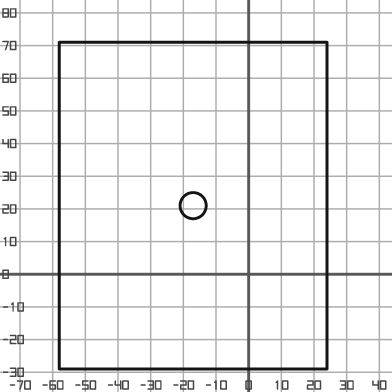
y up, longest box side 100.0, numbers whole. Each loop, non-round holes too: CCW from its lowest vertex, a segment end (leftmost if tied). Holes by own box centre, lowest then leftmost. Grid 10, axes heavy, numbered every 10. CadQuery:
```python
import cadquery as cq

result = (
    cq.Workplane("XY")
    .moveTo(-58.0, -29.0)
    .lineTo(24.0, -29.0)
    .lineTo(24.0, 71.0)
    .lineTo(-58.0, 71.0)
    .close()
    .moveTo(-17.0, 21.0)
    .circle(4.0)
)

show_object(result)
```